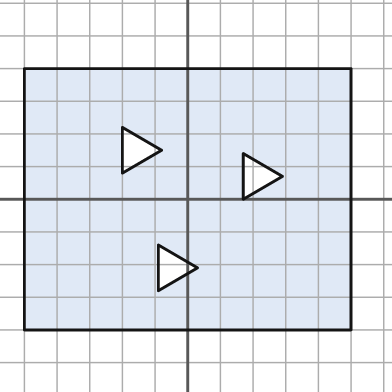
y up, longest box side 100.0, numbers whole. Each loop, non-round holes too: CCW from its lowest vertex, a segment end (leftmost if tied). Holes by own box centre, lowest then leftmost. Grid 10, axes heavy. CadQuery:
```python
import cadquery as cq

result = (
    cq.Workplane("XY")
    .moveTo(-50.0, -40.0)
    .lineTo(50.0, -40.0)
    .lineTo(50.0, 40.0)
    .lineTo(-50.0, 40.0)
    .close()
    .moveTo(-9.0, -28.0)
    .lineTo(3.0, -21.0)
    .lineTo(-9.0, -14.0)
    .close()
    .moveTo(17.0, 0.0)
    .lineTo(29.0, 7.0)
    .lineTo(17.0, 14.0)
    .close()
    .moveTo(-20.0, 8.0)
    .lineTo(-8.0, 15.0)
    .lineTo(-20.0, 22.0)
    .close()
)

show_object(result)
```